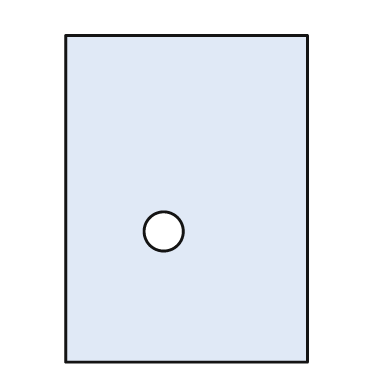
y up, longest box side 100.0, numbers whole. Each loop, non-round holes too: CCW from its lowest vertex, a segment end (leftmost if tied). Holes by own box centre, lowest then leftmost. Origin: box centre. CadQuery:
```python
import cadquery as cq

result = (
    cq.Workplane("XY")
    .moveTo(-37.0, -50.0)
    .lineTo(37.0, -50.0)
    .lineTo(37.0, 50.0)
    .lineTo(-37.0, 50.0)
    .close()
    .moveTo(-7.0, -10.0)
    .circle(6.0)
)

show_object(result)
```